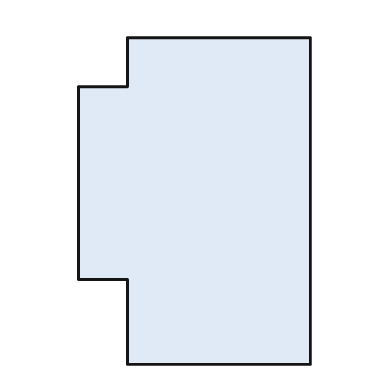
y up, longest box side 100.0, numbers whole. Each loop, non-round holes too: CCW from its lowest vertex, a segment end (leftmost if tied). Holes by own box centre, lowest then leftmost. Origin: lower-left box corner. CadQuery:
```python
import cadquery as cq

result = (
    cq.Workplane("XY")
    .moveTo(15.0, 0.0)
    .lineTo(71.0, 0.0)
    .lineTo(71.0, 100.0)
    .lineTo(15.0, 100.0)
    .lineTo(15.0, 85.0)
    .lineTo(0.0, 85.0)
    .lineTo(0.0, 26.0)
    .lineTo(15.0, 26.0)
    .close()
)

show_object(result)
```